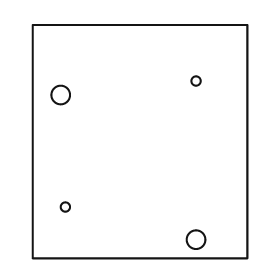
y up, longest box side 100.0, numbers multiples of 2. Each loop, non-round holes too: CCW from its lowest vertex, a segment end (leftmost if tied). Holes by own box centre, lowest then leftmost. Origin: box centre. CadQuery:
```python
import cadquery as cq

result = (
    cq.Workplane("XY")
    .moveTo(-46.0, -50.0)
    .lineTo(46.0, -50.0)
    .lineTo(46.0, 50.0)
    .lineTo(-46.0, 50.0)
    .close()
    .moveTo(24.0, -42.0)
    .circle(4.0)
    .moveTo(-32.0, -28.0)
    .circle(2.0)
    .moveTo(-34.0, 20.0)
    .circle(4.0)
    .moveTo(24.0, 26.0)
    .circle(2.0)
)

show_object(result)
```